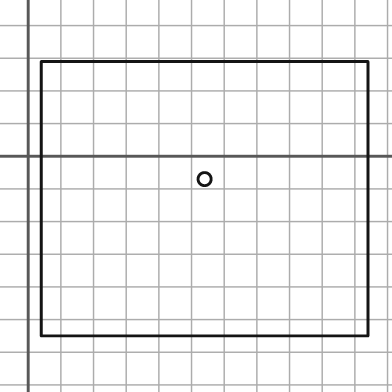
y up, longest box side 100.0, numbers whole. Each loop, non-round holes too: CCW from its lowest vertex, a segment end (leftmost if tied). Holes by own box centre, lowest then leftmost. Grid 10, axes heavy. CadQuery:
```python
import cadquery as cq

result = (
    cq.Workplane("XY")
    .moveTo(4.0, -55.0)
    .lineTo(104.0, -55.0)
    .lineTo(104.0, 29.0)
    .lineTo(4.0, 29.0)
    .close()
    .moveTo(54.0, -7.0)
    .circle(2.0)
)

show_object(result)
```